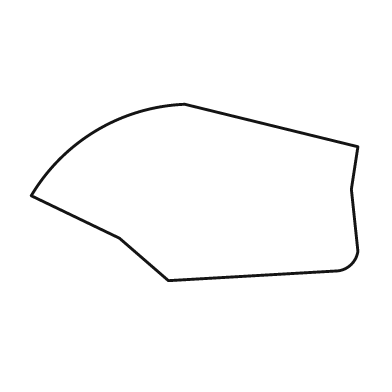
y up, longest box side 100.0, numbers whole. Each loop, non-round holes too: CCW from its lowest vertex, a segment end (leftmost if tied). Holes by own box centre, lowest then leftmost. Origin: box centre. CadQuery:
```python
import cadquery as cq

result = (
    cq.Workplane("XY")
    .moveTo(-8.0, -27.0)
    .lineTo(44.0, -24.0)
    .threePointArc((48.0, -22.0), (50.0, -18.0))
    .lineTo(48.0, 1.0)
    .lineTo(50.0, 14.0)
    .lineTo(-3.0, 27.0)
    .threePointArc((-30.0, 19.0), (-50.0, -1.0))
    .lineTo(-23.0, -14.0)
    .close()
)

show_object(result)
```